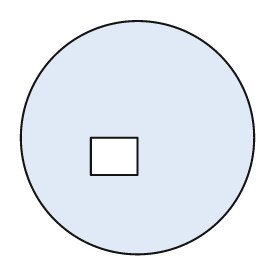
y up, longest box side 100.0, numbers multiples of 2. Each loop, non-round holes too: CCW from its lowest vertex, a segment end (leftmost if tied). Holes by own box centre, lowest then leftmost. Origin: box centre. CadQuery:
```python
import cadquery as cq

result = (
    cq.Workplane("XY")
    .moveTo(0.0, 0.0)
    .circle(50.0)
    .moveTo(-20.0, -16.0)
    .lineTo(0.0, -16.0)
    .lineTo(0.0, 0.0)
    .lineTo(-20.0, 0.0)
    .close()
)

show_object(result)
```